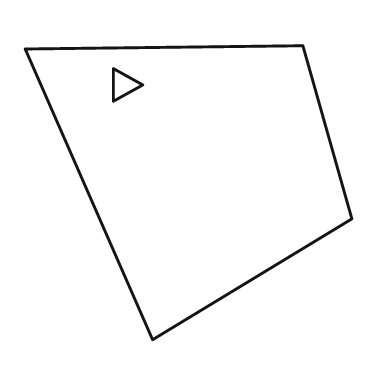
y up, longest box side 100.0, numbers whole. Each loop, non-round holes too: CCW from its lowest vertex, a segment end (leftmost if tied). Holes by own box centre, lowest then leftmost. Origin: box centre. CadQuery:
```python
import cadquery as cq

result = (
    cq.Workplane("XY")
    .moveTo(-11.0, -45.0)
    .lineTo(50.0, -8.0)
    .lineTo(35.0, 45.0)
    .lineTo(-50.0, 44.0)
    .close()
    .moveTo(-23.0, 28.0)
    .lineTo(-14.0, 33.0)
    .lineTo(-23.0, 38.0)
    .close()
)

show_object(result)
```